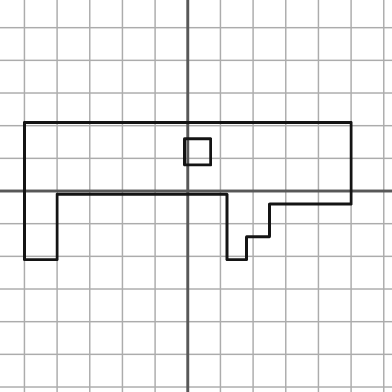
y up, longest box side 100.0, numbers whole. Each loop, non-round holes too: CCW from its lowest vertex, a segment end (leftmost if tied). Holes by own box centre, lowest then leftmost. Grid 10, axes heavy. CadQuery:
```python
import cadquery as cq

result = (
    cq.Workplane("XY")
    .moveTo(-50.0, -21.0)
    .lineTo(-40.0, -21.0)
    .lineTo(-40.0, -1.0)
    .lineTo(12.0, -1.0)
    .lineTo(12.0, -21.0)
    .lineTo(18.0, -21.0)
    .lineTo(18.0, -14.0)
    .lineTo(25.0, -14.0)
    .lineTo(25.0, -4.0)
    .lineTo(50.0, -4.0)
    .lineTo(50.0, 21.0)
    .lineTo(-50.0, 21.0)
    .close()
    .moveTo(-1.0, 8.0)
    .lineTo(7.0, 8.0)
    .lineTo(7.0, 16.0)
    .lineTo(-1.0, 16.0)
    .close()
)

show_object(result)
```